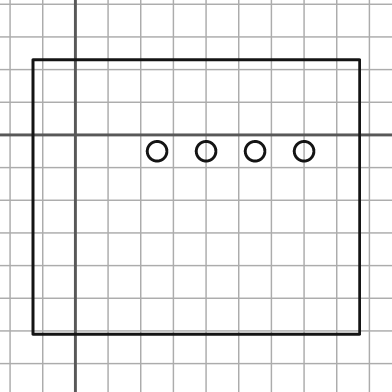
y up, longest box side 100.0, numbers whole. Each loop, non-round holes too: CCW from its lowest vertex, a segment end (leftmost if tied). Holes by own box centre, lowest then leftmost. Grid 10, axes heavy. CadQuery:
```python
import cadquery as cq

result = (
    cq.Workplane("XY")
    .moveTo(-13.0, -61.0)
    .lineTo(87.0, -61.0)
    .lineTo(87.0, 23.0)
    .lineTo(-13.0, 23.0)
    .close()
    .moveTo(25.0, -5.0)
    .circle(3.0)
    .moveTo(40.0, -5.0)
    .circle(3.0)
    .moveTo(55.0, -5.0)
    .circle(3.0)
    .moveTo(70.0, -5.0)
    .circle(3.0)
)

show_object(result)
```